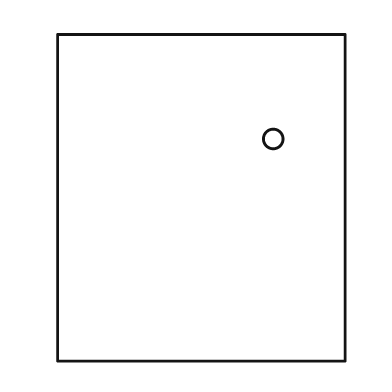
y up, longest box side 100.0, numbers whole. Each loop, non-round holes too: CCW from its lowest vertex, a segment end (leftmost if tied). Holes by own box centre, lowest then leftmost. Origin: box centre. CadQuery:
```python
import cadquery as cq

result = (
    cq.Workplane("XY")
    .moveTo(-44.0, -50.0)
    .lineTo(44.0, -50.0)
    .lineTo(44.0, 50.0)
    .lineTo(-44.0, 50.0)
    .close()
    .moveTo(22.0, 18.0)
    .circle(3.0)
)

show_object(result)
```